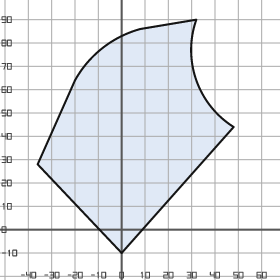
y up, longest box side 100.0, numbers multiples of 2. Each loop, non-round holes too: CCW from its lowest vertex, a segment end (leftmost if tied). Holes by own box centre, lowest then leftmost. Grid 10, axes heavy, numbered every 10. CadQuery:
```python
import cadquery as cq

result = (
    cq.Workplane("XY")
    .moveTo(0.0, -10.0)
    .lineTo(48.0, 44.0)
    .threePointArc((32.0, 64.0), (32.0, 90.0))
    .lineTo(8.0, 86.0)
    .threePointArc((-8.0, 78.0), (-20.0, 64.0))
    .lineTo(-36.0, 28.0)
    .close()
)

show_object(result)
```